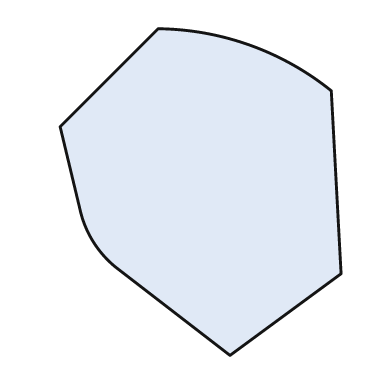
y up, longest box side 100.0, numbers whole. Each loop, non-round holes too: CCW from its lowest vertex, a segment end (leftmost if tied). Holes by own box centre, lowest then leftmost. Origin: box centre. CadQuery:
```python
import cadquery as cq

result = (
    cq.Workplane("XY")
    .moveTo(9.0, -50.0)
    .lineTo(43.0, -25.0)
    .lineTo(40.0, 31.0)
    .threePointArc((15.0, 45.0), (-13.0, 50.0))
    .lineTo(-43.0, 20.0)
    .lineTo(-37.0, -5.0)
    .threePointArc((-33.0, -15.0), (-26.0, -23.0))
    .close()
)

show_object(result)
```